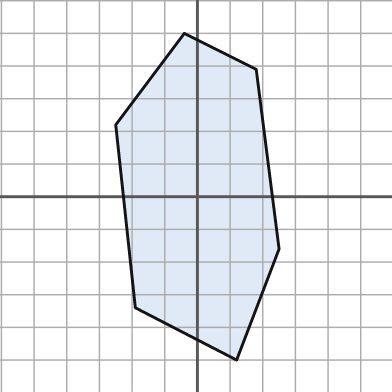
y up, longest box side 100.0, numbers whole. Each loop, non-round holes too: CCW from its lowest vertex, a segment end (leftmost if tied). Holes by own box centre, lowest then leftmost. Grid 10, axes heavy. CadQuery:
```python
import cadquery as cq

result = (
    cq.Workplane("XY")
    .moveTo(12.0, -50.0)
    .lineTo(25.0, -16.0)
    .lineTo(18.0, 39.0)
    .lineTo(-4.0, 50.0)
    .lineTo(-25.0, 22.0)
    .lineTo(-19.0, -34.0)
    .close()
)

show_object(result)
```